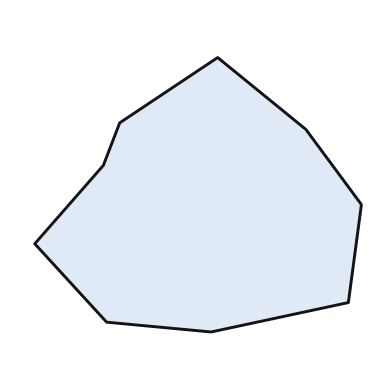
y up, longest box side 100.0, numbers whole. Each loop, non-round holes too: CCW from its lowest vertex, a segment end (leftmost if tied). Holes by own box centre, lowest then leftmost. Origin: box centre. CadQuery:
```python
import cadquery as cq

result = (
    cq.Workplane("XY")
    .moveTo(4.0, -42.0)
    .lineTo(46.0, -33.0)
    .lineTo(50.0, -3.0)
    .lineTo(33.0, 20.0)
    .lineTo(6.0, 42.0)
    .lineTo(-24.0, 22.0)
    .lineTo(-29.0, 9.0)
    .lineTo(-50.0, -15.0)
    .lineTo(-28.0, -39.0)
    .close()
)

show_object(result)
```